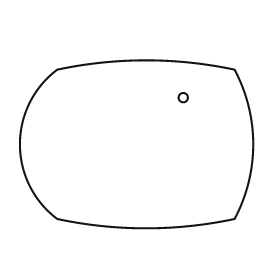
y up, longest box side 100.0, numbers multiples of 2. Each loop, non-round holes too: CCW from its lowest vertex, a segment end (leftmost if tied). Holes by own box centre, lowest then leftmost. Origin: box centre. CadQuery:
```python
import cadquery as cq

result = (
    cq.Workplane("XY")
    .moveTo(-34.0, -32.0)
    .threePointArc((4.0, -36.0), (42.0, -32.0))
    .threePointArc((50.0, 0.0), (42.0, 32.0))
    .threePointArc((4.0, 36.0), (-34.0, 32.0))
    .threePointArc((-50.0, 0.0), (-34.0, -32.0))
    .close()
    .moveTo(20.0, 20.0)
    .circle(2.0)
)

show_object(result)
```